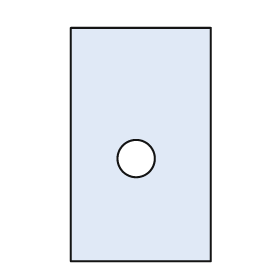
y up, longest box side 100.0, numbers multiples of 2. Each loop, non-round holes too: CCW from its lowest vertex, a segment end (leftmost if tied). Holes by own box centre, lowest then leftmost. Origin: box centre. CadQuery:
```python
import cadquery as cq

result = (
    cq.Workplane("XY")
    .moveTo(-30.0, -50.0)
    .lineTo(30.0, -50.0)
    .lineTo(30.0, 50.0)
    .lineTo(-30.0, 50.0)
    .close()
    .moveTo(-2.0, -6.0)
    .circle(8.0)
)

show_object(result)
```